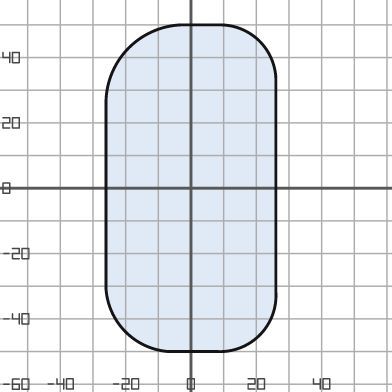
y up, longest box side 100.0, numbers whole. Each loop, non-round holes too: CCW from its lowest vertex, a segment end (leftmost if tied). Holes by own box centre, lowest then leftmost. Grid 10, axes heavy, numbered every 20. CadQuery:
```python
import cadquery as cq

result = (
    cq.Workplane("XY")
    .moveTo(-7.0, -50.0)
    .lineTo(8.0, -50.0)
    .threePointArc((21.0, -45.0), (26.0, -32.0))
    .lineTo(26.0, 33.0)
    .threePointArc((21.0, 45.0), (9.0, 50.0))
    .lineTo(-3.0, 50.0)
    .threePointArc((-19.0, 43.0), (-26.0, 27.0))
    .lineTo(-26.0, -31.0)
    .threePointArc((-20.0, -44.0), (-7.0, -50.0))
    .close()
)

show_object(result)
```